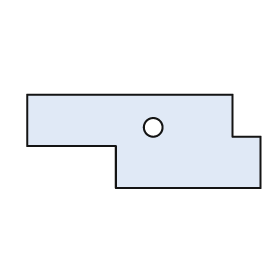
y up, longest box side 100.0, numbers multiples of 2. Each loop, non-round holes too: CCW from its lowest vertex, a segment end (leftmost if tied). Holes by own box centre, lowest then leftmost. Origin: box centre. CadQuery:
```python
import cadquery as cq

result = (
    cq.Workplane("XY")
    .moveTo(-12.0, -20.0)
    .lineTo(50.0, -20.0)
    .lineTo(50.0, 2.0)
    .lineTo(38.0, 2.0)
    .lineTo(38.0, 20.0)
    .lineTo(-50.0, 20.0)
    .lineTo(-50.0, -2.0)
    .lineTo(-12.0, -2.0)
    .close()
    .moveTo(4.0, 6.0)
    .circle(4.0)
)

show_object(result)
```